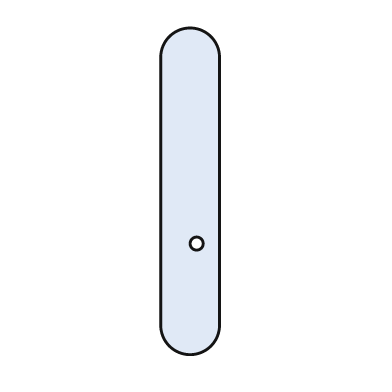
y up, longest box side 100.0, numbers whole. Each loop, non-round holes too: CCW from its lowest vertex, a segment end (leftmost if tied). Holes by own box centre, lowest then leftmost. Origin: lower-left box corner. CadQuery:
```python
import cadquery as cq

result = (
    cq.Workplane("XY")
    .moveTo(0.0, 9.0)
    .threePointArc((9.0, 0.0), (18.0, 9.0))
    .lineTo(18.0, 91.0)
    .threePointArc((9.0, 100.0), (0.0, 91.0))
    .close()
    .moveTo(11.0, 34.0)
    .circle(2.0)
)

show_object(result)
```